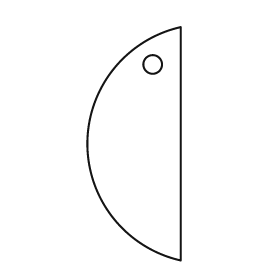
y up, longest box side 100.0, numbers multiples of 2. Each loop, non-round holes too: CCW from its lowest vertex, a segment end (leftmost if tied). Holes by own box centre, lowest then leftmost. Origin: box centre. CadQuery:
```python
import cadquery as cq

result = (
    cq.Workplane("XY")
    .moveTo(20.0, -50.0)
    .lineTo(20.0, 50.0)
    .threePointArc((-20.0, 0.0), (20.0, -50.0))
    .close()
    .moveTo(8.0, 34.0)
    .circle(4.0)
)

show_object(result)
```